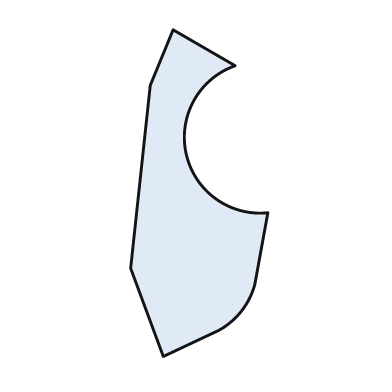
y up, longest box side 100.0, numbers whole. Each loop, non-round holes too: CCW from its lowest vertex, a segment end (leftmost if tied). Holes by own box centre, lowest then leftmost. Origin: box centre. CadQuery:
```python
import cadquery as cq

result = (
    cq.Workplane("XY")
    .moveTo(-11.0, -50.0)
    .lineTo(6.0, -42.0)
    .threePointArc((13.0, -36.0), (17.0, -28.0))
    .lineTo(21.0, -6.0)
    .threePointArc((-4.0, 12.0), (11.0, 39.0))
    .lineTo(-8.0, 50.0)
    .lineTo(-15.0, 33.0)
    .lineTo(-21.0, -23.0)
    .close()
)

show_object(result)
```